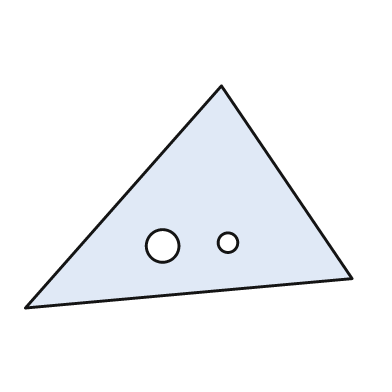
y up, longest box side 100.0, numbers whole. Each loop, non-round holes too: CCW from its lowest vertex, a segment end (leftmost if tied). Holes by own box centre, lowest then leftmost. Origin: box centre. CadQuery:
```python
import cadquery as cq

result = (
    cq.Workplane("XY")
    .moveTo(-50.0, -34.0)
    .lineTo(50.0, -25.0)
    .lineTo(10.0, 34.0)
    .close()
    .moveTo(-8.0, -15.0)
    .circle(5.0)
    .moveTo(12.0, -14.0)
    .circle(3.0)
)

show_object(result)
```